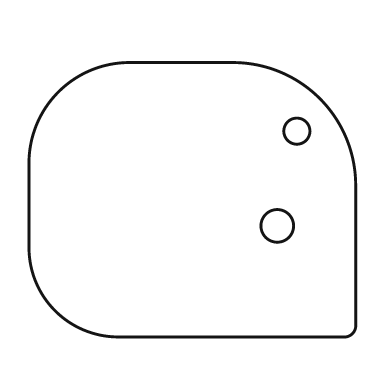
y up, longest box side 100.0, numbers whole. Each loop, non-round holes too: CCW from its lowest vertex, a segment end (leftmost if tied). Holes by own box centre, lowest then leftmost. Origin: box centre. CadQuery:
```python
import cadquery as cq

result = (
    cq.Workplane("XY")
    .moveTo(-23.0, -42.0)
    .lineTo(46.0, -42.0)
    .threePointArc((49.0, -41.0), (50.0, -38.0))
    .lineTo(50.0, 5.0)
    .threePointArc((39.0, 31.0), (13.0, 42.0))
    .lineTo(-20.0, 42.0)
    .threePointArc((-41.0, 33.0), (-50.0, 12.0))
    .lineTo(-50.0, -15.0)
    .threePointArc((-42.0, -34.0), (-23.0, -42.0))
    .close()
    .moveTo(26.0, -8.0)
    .circle(5.0)
    .moveTo(32.0, 21.0)
    .circle(4.0)
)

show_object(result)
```